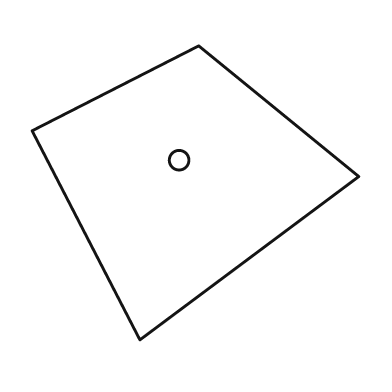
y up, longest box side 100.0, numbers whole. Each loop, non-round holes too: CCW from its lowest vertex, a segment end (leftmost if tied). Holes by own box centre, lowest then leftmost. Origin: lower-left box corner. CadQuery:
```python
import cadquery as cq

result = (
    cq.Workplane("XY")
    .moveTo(33.0, 0.0)
    .lineTo(100.0, 50.0)
    .lineTo(51.0, 90.0)
    .lineTo(0.0, 64.0)
    .close()
    .moveTo(45.0, 55.0)
    .circle(3.0)
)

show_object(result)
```